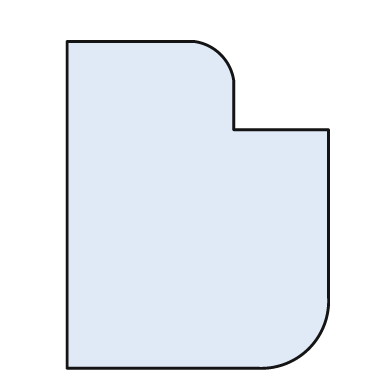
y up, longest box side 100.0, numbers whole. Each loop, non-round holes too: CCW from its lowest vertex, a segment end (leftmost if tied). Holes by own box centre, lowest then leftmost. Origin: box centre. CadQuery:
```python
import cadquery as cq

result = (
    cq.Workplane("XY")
    .moveTo(-40.0, -50.0)
    .lineTo(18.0, -50.0)
    .threePointArc((34.0, -44.0), (40.0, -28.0))
    .lineTo(40.0, 23.0)
    .lineTo(11.0, 23.0)
    .lineTo(11.0, 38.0)
    .threePointArc((7.0, 46.0), (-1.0, 50.0))
    .lineTo(-40.0, 50.0)
    .close()
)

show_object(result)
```